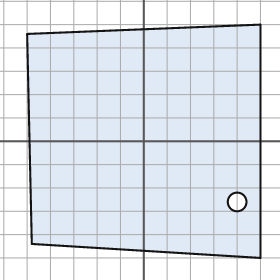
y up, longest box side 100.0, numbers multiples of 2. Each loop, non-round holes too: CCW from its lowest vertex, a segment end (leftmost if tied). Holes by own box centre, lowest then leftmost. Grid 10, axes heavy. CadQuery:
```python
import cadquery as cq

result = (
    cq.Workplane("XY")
    .moveTo(50.0, -50.0)
    .lineTo(50.0, 50.0)
    .lineTo(-50.0, 46.0)
    .lineTo(-48.0, -44.0)
    .close()
    .moveTo(40.0, -26.0)
    .circle(4.0)
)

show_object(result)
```